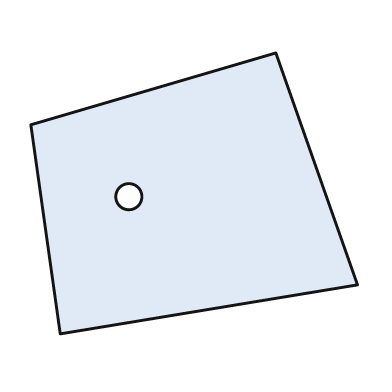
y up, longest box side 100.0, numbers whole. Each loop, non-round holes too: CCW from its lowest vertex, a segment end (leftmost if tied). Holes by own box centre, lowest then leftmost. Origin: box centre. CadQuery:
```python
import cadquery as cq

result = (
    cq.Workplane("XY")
    .moveTo(-41.0, -43.0)
    .lineTo(50.0, -28.0)
    .lineTo(25.0, 43.0)
    .lineTo(-50.0, 21.0)
    .close()
    .moveTo(-20.0, -1.0)
    .circle(4.0)
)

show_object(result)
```